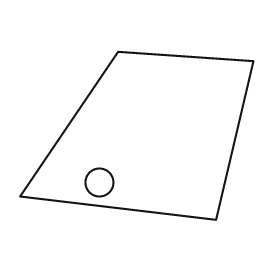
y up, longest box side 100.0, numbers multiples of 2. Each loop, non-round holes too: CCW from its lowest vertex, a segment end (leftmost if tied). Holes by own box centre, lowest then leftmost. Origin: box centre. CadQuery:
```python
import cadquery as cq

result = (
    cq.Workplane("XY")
    .moveTo(34.0, -36.0)
    .lineTo(50.0, 32.0)
    .lineTo(-8.0, 36.0)
    .lineTo(-50.0, -26.0)
    .close()
    .moveTo(-16.0, -20.0)
    .circle(6.0)
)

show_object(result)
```